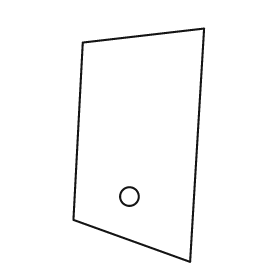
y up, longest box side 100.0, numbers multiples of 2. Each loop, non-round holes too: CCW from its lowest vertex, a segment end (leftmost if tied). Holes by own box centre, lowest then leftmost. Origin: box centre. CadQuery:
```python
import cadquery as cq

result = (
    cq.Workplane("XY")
    .moveTo(22.0, -50.0)
    .lineTo(28.0, 50.0)
    .lineTo(-24.0, 44.0)
    .lineTo(-28.0, -32.0)
    .close()
    .moveTo(-4.0, -22.0)
    .circle(4.0)
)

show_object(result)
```